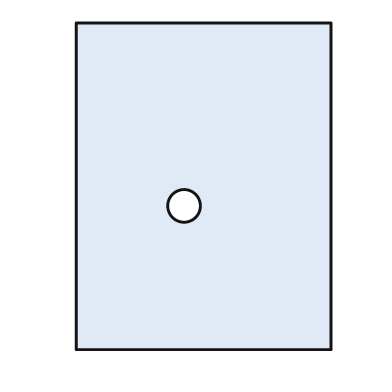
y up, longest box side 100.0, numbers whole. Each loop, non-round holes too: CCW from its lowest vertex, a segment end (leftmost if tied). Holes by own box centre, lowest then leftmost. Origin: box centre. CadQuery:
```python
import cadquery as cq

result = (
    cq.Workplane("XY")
    .moveTo(-39.0, -50.0)
    .lineTo(39.0, -50.0)
    .lineTo(39.0, 50.0)
    .lineTo(-39.0, 50.0)
    .close()
    .moveTo(-6.0, -6.0)
    .circle(5.0)
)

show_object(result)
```